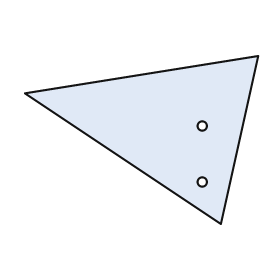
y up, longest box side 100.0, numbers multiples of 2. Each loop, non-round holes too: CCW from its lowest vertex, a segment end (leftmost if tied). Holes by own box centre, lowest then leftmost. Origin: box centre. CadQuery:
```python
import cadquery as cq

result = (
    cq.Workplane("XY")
    .moveTo(34.0, -36.0)
    .lineTo(50.0, 36.0)
    .lineTo(-50.0, 20.0)
    .close()
    .moveTo(26.0, -18.0)
    .circle(2.0)
    .moveTo(26.0, 6.0)
    .circle(2.0)
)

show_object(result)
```